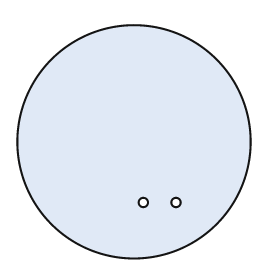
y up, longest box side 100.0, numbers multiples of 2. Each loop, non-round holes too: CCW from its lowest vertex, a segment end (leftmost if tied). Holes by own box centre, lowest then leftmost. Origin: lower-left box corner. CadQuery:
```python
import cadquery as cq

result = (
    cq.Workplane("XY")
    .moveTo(50.0, 50.0)
    .circle(50.0)
    .moveTo(54.0, 24.0)
    .circle(2.0)
    .moveTo(68.0, 24.0)
    .circle(2.0)
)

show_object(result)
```